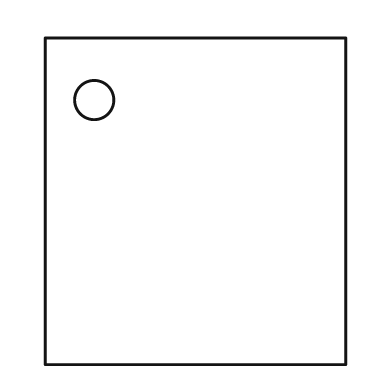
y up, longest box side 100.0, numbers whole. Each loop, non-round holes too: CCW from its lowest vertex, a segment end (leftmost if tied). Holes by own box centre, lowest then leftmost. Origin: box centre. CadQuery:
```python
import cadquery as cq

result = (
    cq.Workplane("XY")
    .moveTo(-46.0, -50.0)
    .lineTo(46.0, -50.0)
    .lineTo(46.0, 50.0)
    .lineTo(-46.0, 50.0)
    .close()
    .moveTo(-31.0, 31.0)
    .circle(6.0)
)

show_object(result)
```